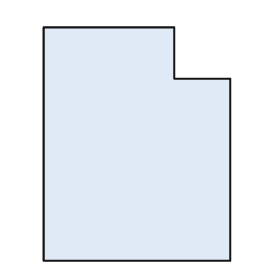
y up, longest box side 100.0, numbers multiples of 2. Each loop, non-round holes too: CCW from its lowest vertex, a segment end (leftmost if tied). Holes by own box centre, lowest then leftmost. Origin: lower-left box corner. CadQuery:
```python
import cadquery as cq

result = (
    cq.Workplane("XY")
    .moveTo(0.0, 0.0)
    .lineTo(80.0, 0.0)
    .lineTo(80.0, 78.0)
    .lineTo(56.0, 78.0)
    .lineTo(56.0, 100.0)
    .lineTo(0.0, 100.0)
    .close()
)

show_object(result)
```